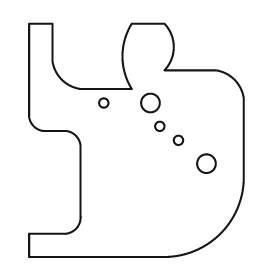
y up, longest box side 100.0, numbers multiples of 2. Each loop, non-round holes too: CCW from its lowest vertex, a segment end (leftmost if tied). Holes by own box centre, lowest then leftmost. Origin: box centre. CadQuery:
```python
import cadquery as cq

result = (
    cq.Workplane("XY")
    .moveTo(-46.0, -50.0)
    .lineTo(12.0, -50.0)
    .threePointArc((36.0, -40.0), (46.0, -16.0))
    .lineTo(46.0, 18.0)
    .threePointArc((42.0, 26.0), (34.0, 30.0))
    .lineTo(12.0, 30.0)
    .threePointArc((16.0, 40.0), (12.0, 50.0))
    .lineTo(-2.0, 50.0)
    .threePointArc((-6.0, 36.0), (-2.0, 22.0))
    .lineTo(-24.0, 22.0)
    .threePointArc((-32.0, 26.0), (-36.0, 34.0))
    .lineTo(-36.0, 50.0)
    .lineTo(-46.0, 50.0)
    .lineTo(-46.0, 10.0)
    .threePointArc((-44.0, 6.0), (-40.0, 4.0))
    .lineTo(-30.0, 4.0)
    .threePointArc((-26.0, 2.0), (-24.0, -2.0))
    .lineTo(-24.0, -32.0)
    .threePointArc((-26.0, -38.0), (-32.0, -40.0))
    .lineTo(-46.0, -40.0)
    .close()
    .moveTo(30.0, -10.0)
    .circle(4.0)
    .moveTo(18.0, 0.0)
    .circle(2.0)
    .moveTo(10.0, 6.0)
    .circle(2.0)
    .moveTo(-14.0, 16.0)
    .circle(2.0)
    .moveTo(6.0, 16.0)
    .circle(4.0)
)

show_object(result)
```